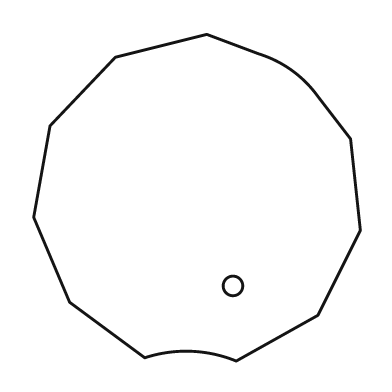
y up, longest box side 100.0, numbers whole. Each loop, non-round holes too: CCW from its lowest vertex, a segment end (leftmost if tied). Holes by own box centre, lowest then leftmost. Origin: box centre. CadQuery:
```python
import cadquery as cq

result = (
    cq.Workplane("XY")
    .moveTo(12.0, -50.0)
    .lineTo(37.0, -36.0)
    .lineTo(50.0, -10.0)
    .lineTo(47.0, 18.0)
    .lineTo(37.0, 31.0)
    .threePointArc((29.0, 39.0), (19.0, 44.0))
    .lineTo(3.0, 50.0)
    .lineTo(-25.0, 43.0)
    .lineTo(-45.0, 22.0)
    .lineTo(-50.0, -6.0)
    .lineTo(-39.0, -32.0)
    .lineTo(-16.0, -49.0)
    .threePointArc((-2.0, -47.0), (12.0, -50.0))
    .close()
    .moveTo(11.0, -27.0)
    .circle(3.0)
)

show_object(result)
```